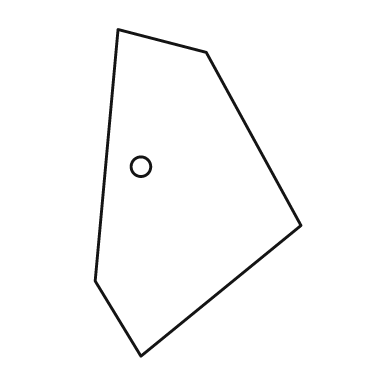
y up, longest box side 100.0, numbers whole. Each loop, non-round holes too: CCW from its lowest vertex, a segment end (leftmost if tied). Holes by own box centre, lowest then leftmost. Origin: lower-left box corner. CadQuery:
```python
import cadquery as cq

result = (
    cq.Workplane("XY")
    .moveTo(14.0, 0.0)
    .lineTo(63.0, 40.0)
    .lineTo(34.0, 93.0)
    .lineTo(7.0, 100.0)
    .lineTo(0.0, 23.0)
    .close()
    .moveTo(14.0, 58.0)
    .circle(3.0)
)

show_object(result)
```